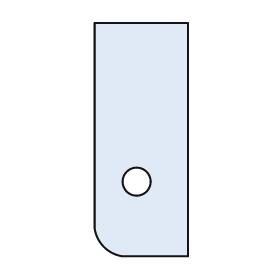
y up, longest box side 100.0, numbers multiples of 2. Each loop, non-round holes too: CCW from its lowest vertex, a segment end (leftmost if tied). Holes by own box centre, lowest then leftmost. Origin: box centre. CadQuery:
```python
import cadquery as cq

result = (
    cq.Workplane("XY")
    .moveTo(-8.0, -50.0)
    .lineTo(20.0, -50.0)
    .lineTo(20.0, 50.0)
    .lineTo(-20.0, 50.0)
    .lineTo(-20.0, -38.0)
    .threePointArc((-16.0, -46.0), (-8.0, -50.0))
    .close()
    .moveTo(-2.0, -18.0)
    .circle(6.0)
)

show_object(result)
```